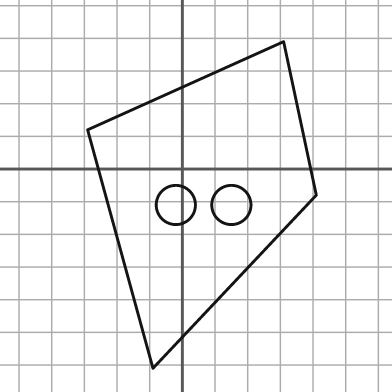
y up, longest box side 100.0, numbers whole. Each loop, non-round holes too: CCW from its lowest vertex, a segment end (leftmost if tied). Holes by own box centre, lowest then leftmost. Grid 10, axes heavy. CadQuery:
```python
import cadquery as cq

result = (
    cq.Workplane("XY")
    .moveTo(-9.0, -61.0)
    .lineTo(41.0, -8.0)
    .lineTo(31.0, 39.0)
    .lineTo(-29.0, 12.0)
    .close()
    .moveTo(-2.0, -11.0)
    .circle(6.0)
    .moveTo(15.0, -11.0)
    .circle(6.0)
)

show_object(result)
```